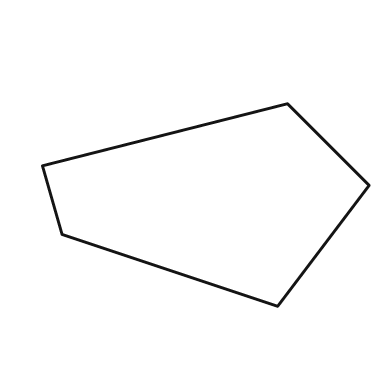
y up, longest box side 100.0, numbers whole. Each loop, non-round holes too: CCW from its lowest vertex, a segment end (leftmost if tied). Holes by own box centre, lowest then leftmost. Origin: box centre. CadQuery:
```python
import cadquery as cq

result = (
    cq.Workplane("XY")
    .moveTo(22.0, -31.0)
    .lineTo(50.0, 6.0)
    .lineTo(25.0, 31.0)
    .lineTo(-50.0, 12.0)
    .lineTo(-44.0, -9.0)
    .close()
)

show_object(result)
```